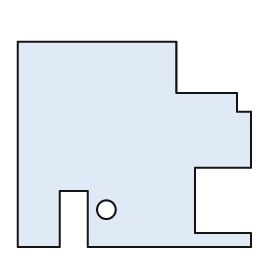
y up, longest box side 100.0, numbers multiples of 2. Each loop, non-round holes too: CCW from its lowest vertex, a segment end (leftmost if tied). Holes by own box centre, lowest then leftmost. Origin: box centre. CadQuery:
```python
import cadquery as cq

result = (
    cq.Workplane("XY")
    .moveTo(-50.0, -44.0)
    .lineTo(-32.0, -44.0)
    .lineTo(-32.0, -20.0)
    .lineTo(-20.0, -20.0)
    .lineTo(-20.0, -44.0)
    .lineTo(50.0, -44.0)
    .lineTo(50.0, -38.0)
    .lineTo(26.0, -38.0)
    .lineTo(26.0, -10.0)
    .lineTo(50.0, -10.0)
    .lineTo(50.0, 14.0)
    .lineTo(44.0, 14.0)
    .lineTo(44.0, 22.0)
    .lineTo(18.0, 22.0)
    .lineTo(18.0, 44.0)
    .lineTo(-50.0, 44.0)
    .close()
    .moveTo(-12.0, -28.0)
    .circle(4.0)
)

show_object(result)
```